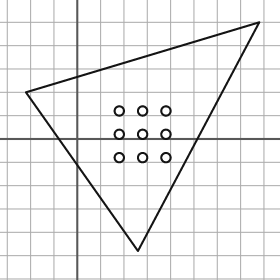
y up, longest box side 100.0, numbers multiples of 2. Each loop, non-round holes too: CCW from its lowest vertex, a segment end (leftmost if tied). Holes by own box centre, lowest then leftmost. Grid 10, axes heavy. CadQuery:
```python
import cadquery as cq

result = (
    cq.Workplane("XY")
    .moveTo(26.0, -48.0)
    .lineTo(78.0, 50.0)
    .lineTo(-22.0, 20.0)
    .close()
    .moveTo(18.0, -8.0)
    .circle(2.0)
    .moveTo(28.0, -8.0)
    .circle(2.0)
    .moveTo(38.0, -8.0)
    .circle(2.0)
    .moveTo(18.0, 2.0)
    .circle(2.0)
    .moveTo(28.0, 2.0)
    .circle(2.0)
    .moveTo(38.0, 2.0)
    .circle(2.0)
    .moveTo(18.0, 12.0)
    .circle(2.0)
    .moveTo(28.0, 12.0)
    .circle(2.0)
    .moveTo(38.0, 12.0)
    .circle(2.0)
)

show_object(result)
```